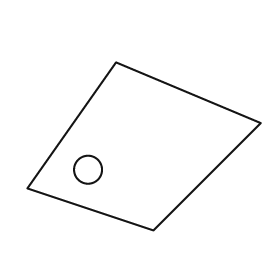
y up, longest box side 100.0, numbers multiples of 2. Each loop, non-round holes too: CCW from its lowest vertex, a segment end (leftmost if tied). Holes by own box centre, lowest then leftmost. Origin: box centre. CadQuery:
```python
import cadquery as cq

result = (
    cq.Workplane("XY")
    .moveTo(4.0, -36.0)
    .lineTo(50.0, 10.0)
    .lineTo(-12.0, 36.0)
    .lineTo(-50.0, -18.0)
    .close()
    .moveTo(-24.0, -10.0)
    .circle(6.0)
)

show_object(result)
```